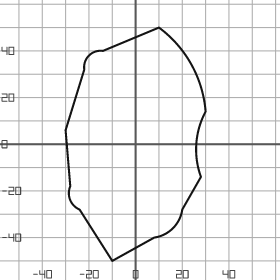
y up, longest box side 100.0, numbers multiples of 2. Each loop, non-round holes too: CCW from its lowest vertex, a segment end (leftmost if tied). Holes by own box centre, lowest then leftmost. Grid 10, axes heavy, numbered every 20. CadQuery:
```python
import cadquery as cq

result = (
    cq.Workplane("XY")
    .moveTo(-10.0, -50.0)
    .lineTo(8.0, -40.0)
    .threePointArc((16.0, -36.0), (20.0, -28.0))
    .lineTo(28.0, -14.0)
    .threePointArc((26.0, 0.0), (30.0, 14.0))
    .threePointArc((24.0, 34.0), (10.0, 50.0))
    .lineTo(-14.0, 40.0)
    .threePointArc((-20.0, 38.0), (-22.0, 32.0))
    .lineTo(-30.0, 6.0)
    .lineTo(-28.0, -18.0)
    .threePointArc((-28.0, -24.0), (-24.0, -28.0))
    .close()
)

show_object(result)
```